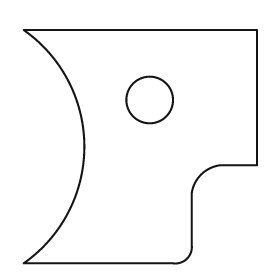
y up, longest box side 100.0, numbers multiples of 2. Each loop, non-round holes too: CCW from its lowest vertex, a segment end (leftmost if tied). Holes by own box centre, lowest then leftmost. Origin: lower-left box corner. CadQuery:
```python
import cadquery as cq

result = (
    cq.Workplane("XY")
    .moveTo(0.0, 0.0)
    .lineTo(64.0, 0.0)
    .threePointArc((70.0, 2.0), (72.0, 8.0))
    .lineTo(72.0, 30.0)
    .threePointArc((76.0, 38.0), (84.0, 42.0))
    .lineTo(100.0, 42.0)
    .lineTo(100.0, 100.0)
    .lineTo(0.0, 100.0)
    .threePointArc((26.0, 50.0), (0.0, 0.0))
    .close()
    .moveTo(54.0, 70.0)
    .circle(10.0)
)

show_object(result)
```